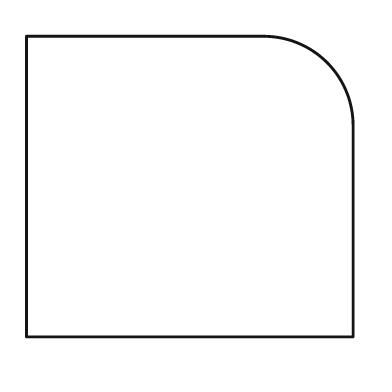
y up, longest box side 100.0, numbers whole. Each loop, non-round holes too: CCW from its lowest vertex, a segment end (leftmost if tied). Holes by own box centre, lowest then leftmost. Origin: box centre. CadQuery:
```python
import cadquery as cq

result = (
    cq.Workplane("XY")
    .moveTo(-50.0, -46.0)
    .lineTo(50.0, -46.0)
    .lineTo(50.0, 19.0)
    .threePointArc((42.0, 38.0), (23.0, 46.0))
    .lineTo(-50.0, 46.0)
    .close()
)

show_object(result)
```